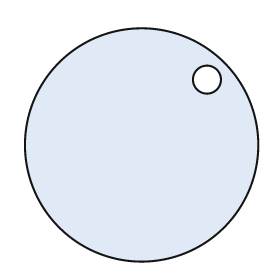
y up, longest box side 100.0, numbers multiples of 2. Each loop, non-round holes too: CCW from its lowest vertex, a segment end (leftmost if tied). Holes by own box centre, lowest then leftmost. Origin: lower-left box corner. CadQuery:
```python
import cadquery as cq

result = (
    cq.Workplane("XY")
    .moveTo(50.0, 50.0)
    .circle(50.0)
    .moveTo(78.0, 78.0)
    .circle(6.0)
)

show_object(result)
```